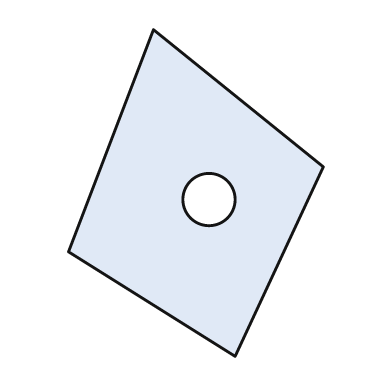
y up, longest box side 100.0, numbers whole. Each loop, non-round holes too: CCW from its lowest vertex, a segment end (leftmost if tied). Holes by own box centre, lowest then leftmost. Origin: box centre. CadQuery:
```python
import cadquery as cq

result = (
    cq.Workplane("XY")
    .moveTo(12.0, -50.0)
    .lineTo(39.0, 8.0)
    .lineTo(-13.0, 50.0)
    .lineTo(-39.0, -18.0)
    .close()
    .moveTo(4.0, -2.0)
    .circle(8.0)
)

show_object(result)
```